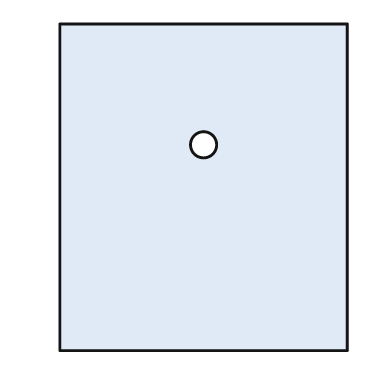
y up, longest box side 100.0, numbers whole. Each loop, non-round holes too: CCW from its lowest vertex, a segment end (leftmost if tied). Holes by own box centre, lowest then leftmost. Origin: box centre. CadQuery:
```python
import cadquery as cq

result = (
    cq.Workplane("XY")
    .moveTo(-44.0, -50.0)
    .lineTo(44.0, -50.0)
    .lineTo(44.0, 50.0)
    .lineTo(-44.0, 50.0)
    .close()
    .moveTo(0.0, 13.0)
    .circle(4.0)
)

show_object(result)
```